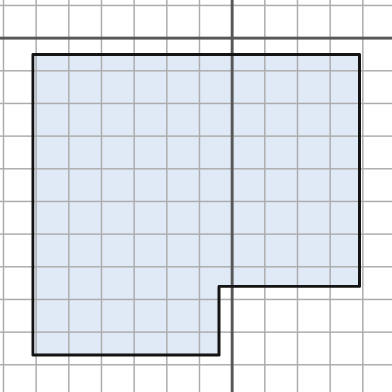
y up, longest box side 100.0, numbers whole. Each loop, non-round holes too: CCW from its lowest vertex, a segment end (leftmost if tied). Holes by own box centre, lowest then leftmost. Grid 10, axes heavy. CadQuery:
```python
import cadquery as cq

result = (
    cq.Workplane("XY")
    .moveTo(-61.0, -97.0)
    .lineTo(-4.0, -97.0)
    .lineTo(-4.0, -76.0)
    .lineTo(39.0, -76.0)
    .lineTo(39.0, -5.0)
    .lineTo(-61.0, -5.0)
    .close()
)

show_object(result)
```